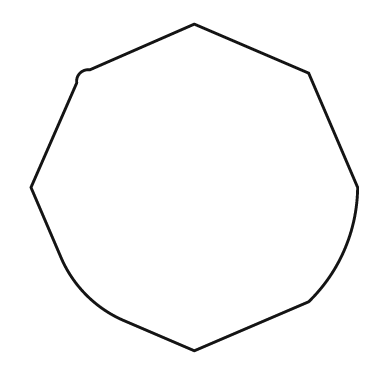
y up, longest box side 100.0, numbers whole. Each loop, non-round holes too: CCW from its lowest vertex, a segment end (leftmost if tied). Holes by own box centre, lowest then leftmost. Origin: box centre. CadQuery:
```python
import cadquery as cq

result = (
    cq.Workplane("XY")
    .moveTo(0.0, -50.0)
    .lineTo(35.0, -35.0)
    .threePointArc((46.0, -19.0), (50.0, 0.0))
    .lineTo(35.0, 35.0)
    .lineTo(0.0, 50.0)
    .lineTo(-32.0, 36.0)
    .threePointArc((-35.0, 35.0), (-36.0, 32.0))
    .lineTo(-50.0, 0.0)
    .lineTo(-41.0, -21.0)
    .threePointArc((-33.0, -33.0), (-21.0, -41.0))
    .close()
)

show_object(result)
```